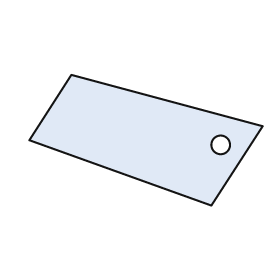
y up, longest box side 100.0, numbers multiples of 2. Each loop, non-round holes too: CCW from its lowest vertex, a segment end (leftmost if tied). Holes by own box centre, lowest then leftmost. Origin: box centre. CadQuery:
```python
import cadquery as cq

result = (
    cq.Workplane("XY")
    .moveTo(28.0, -28.0)
    .lineTo(50.0, 6.0)
    .lineTo(-32.0, 28.0)
    .lineTo(-50.0, 0.0)
    .close()
    .moveTo(32.0, -2.0)
    .circle(4.0)
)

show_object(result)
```